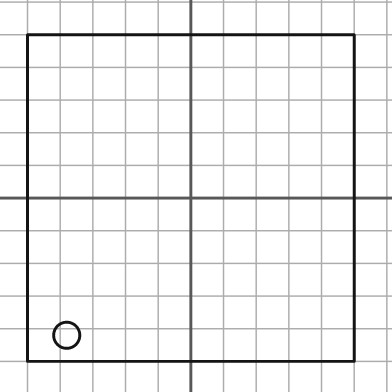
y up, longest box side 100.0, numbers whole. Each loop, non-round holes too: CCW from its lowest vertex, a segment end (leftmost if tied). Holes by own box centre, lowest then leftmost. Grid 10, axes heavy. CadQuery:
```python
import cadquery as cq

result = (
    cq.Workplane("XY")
    .moveTo(-50.0, -50.0)
    .lineTo(50.0, -50.0)
    .lineTo(50.0, 50.0)
    .lineTo(-50.0, 50.0)
    .close()
    .moveTo(-38.0, -42.0)
    .circle(4.0)
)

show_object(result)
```